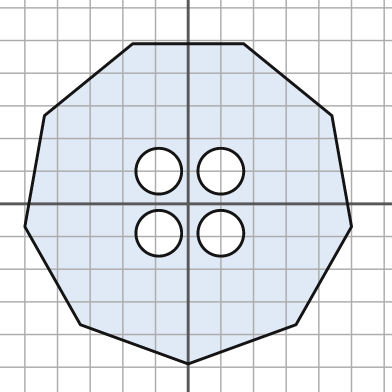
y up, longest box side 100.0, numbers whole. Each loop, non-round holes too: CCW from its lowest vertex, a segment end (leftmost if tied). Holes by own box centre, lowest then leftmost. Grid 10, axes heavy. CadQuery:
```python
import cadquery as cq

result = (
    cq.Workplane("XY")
    .moveTo(0.0, -49.0)
    .lineTo(33.0, -37.0)
    .lineTo(50.0, -7.0)
    .lineTo(44.0, 27.0)
    .lineTo(17.0, 49.0)
    .lineTo(-17.0, 49.0)
    .lineTo(-44.0, 27.0)
    .lineTo(-50.0, -7.0)
    .lineTo(-33.0, -37.0)
    .close()
    .moveTo(-9.0, -9.0)
    .circle(7.0)
    .moveTo(10.0, -9.0)
    .circle(7.0)
    .moveTo(-9.0, 10.0)
    .circle(7.0)
    .moveTo(10.0, 10.0)
    .circle(7.0)
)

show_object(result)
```